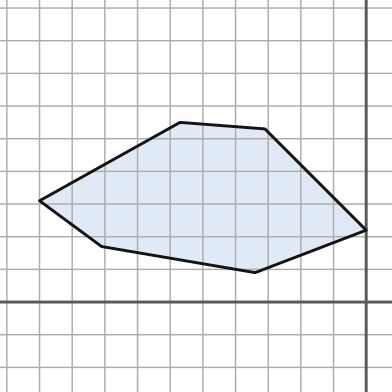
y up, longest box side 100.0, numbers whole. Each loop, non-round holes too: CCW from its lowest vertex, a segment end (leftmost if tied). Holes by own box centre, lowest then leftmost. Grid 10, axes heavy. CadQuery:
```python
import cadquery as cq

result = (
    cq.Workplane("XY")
    .moveTo(-34.0, 9.0)
    .lineTo(0.0, 22.0)
    .lineTo(-31.0, 53.0)
    .lineTo(-57.0, 55.0)
    .lineTo(-100.0, 31.0)
    .lineTo(-81.0, 17.0)
    .close()
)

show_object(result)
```